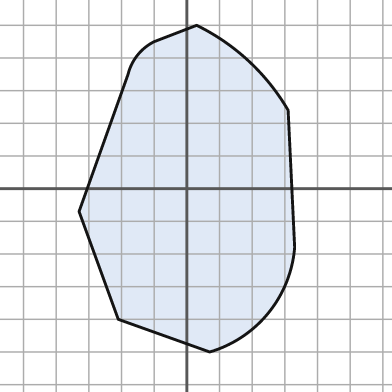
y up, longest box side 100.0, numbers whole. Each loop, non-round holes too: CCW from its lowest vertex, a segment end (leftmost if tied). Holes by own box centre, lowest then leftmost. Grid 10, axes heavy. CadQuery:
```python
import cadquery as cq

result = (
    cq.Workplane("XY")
    .moveTo(7.0, -50.0)
    .threePointArc((25.0, -38.0), (33.0, -18.0))
    .lineTo(31.0, 24.0)
    .threePointArc((19.0, 39.0), (3.0, 50.0))
    .lineTo(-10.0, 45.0)
    .threePointArc((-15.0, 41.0), (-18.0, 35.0))
    .lineTo(-33.0, -7.0)
    .lineTo(-21.0, -40.0)
    .close()
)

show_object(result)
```